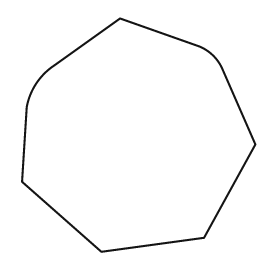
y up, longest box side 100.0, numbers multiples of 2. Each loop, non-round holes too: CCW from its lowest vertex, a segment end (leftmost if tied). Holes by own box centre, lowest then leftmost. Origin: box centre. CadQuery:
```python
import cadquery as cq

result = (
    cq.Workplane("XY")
    .moveTo(-16.0, -50.0)
    .lineTo(28.0, -44.0)
    .lineTo(50.0, -4.0)
    .lineTo(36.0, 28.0)
    .threePointArc((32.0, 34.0), (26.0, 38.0))
    .lineTo(-8.0, 50.0)
    .lineTo(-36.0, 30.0)
    .threePointArc((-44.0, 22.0), (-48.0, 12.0))
    .lineTo(-50.0, -20.0)
    .close()
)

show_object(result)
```